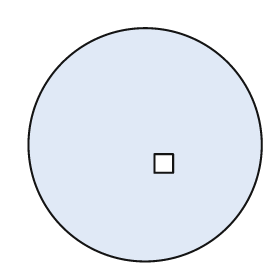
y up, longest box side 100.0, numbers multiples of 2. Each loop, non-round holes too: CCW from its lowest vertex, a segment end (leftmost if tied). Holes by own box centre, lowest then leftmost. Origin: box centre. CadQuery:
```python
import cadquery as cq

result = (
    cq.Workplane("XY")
    .moveTo(0.0, 0.0)
    .circle(50.0)
    .moveTo(4.0, -12.0)
    .lineTo(12.0, -12.0)
    .lineTo(12.0, -4.0)
    .lineTo(4.0, -4.0)
    .close()
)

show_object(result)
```